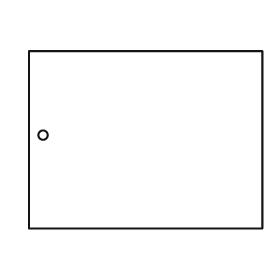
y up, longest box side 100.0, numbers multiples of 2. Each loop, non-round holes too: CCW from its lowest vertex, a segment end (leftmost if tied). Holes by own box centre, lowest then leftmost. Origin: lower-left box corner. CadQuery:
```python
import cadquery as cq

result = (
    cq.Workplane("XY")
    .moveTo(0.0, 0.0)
    .lineTo(100.0, 0.0)
    .lineTo(100.0, 76.0)
    .lineTo(0.0, 76.0)
    .close()
    .moveTo(6.0, 40.0)
    .circle(2.0)
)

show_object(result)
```